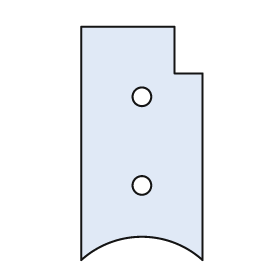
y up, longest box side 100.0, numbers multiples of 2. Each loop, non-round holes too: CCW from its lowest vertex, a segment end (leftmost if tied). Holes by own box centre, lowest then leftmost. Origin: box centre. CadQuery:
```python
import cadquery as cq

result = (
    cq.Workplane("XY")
    .moveTo(-26.0, -50.0)
    .threePointArc((0.0, -40.0), (26.0, -50.0))
    .lineTo(26.0, 30.0)
    .lineTo(14.0, 30.0)
    .lineTo(14.0, 50.0)
    .lineTo(-26.0, 50.0)
    .close()
    .moveTo(0.0, -18.0)
    .circle(4.0)
    .moveTo(0.0, 20.0)
    .circle(4.0)
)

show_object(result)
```